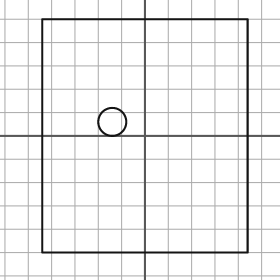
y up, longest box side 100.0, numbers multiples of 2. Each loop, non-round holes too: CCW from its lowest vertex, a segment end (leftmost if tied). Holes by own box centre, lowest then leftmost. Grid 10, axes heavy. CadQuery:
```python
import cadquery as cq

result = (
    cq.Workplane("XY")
    .moveTo(-44.0, -50.0)
    .lineTo(44.0, -50.0)
    .lineTo(44.0, 50.0)
    .lineTo(-44.0, 50.0)
    .close()
    .moveTo(-14.0, 6.0)
    .circle(6.0)
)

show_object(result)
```